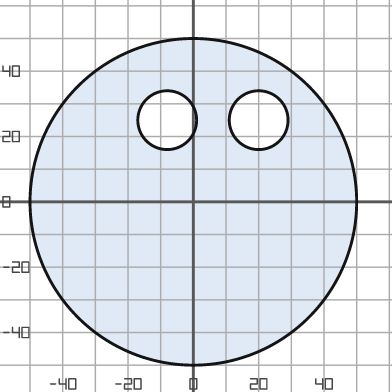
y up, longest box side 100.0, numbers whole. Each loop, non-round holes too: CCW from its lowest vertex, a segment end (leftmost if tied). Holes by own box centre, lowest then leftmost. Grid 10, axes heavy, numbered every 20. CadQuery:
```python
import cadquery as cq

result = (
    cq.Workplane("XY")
    .moveTo(0.0, 0.0)
    .circle(50.0)
    .moveTo(-8.0, 25.0)
    .circle(9.0)
    .moveTo(20.0, 25.0)
    .circle(9.0)
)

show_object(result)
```